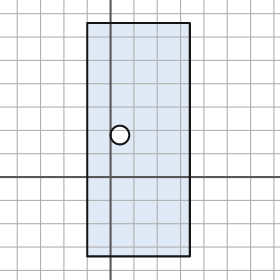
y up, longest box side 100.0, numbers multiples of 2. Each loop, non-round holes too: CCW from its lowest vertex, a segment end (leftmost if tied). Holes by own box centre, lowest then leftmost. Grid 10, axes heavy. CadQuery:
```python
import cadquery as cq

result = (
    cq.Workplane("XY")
    .moveTo(-10.0, -34.0)
    .lineTo(34.0, -34.0)
    .lineTo(34.0, 66.0)
    .lineTo(-10.0, 66.0)
    .close()
    .moveTo(4.0, 18.0)
    .circle(4.0)
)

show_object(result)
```